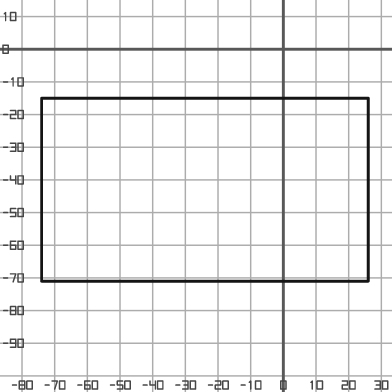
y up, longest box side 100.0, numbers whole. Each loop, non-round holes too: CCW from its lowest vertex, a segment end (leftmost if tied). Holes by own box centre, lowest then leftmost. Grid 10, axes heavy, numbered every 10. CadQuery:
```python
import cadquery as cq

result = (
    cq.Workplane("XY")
    .moveTo(-74.0, -71.0)
    .lineTo(26.0, -71.0)
    .lineTo(26.0, -15.0)
    .lineTo(-74.0, -15.0)
    .close()
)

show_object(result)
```